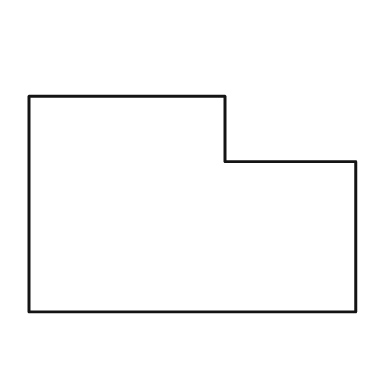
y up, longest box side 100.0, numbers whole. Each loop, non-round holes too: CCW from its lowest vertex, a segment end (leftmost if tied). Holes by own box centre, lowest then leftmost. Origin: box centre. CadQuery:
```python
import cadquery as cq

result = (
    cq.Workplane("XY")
    .moveTo(-50.0, -33.0)
    .lineTo(50.0, -33.0)
    .lineTo(50.0, 13.0)
    .lineTo(10.0, 13.0)
    .lineTo(10.0, 33.0)
    .lineTo(-50.0, 33.0)
    .close()
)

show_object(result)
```